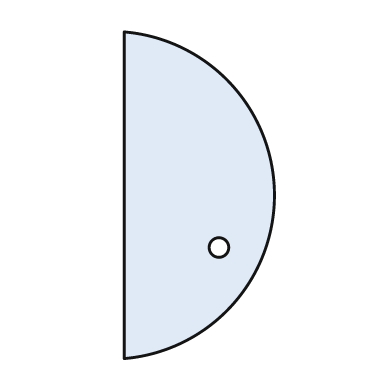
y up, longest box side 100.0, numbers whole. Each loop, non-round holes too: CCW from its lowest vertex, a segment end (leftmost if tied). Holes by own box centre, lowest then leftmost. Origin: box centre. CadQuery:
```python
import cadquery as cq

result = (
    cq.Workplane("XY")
    .moveTo(-23.0, -50.0)
    .threePointArc((23.0, 0.0), (-23.0, 50.0))
    .close()
    .moveTo(6.0, -16.0)
    .circle(3.0)
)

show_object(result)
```